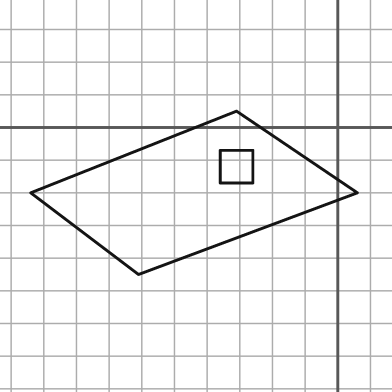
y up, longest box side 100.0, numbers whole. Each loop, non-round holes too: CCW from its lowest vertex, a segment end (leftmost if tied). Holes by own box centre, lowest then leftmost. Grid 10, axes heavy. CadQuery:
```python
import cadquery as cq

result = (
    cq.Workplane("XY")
    .moveTo(-61.0, -45.0)
    .lineTo(6.0, -20.0)
    .lineTo(-31.0, 5.0)
    .lineTo(-94.0, -20.0)
    .close()
    .moveTo(-36.0, -17.0)
    .lineTo(-26.0, -17.0)
    .lineTo(-26.0, -7.0)
    .lineTo(-36.0, -7.0)
    .close()
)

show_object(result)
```